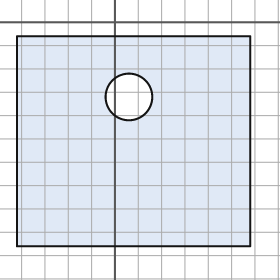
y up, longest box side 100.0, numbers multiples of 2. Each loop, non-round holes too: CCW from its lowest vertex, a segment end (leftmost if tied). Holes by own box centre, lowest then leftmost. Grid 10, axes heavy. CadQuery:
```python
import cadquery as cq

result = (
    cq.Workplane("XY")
    .moveTo(-42.0, -96.0)
    .lineTo(58.0, -96.0)
    .lineTo(58.0, -6.0)
    .lineTo(-42.0, -6.0)
    .close()
    .moveTo(6.0, -32.0)
    .circle(10.0)
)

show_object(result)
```